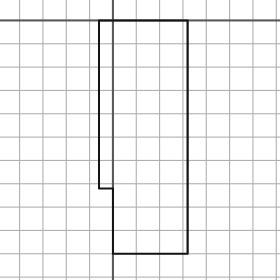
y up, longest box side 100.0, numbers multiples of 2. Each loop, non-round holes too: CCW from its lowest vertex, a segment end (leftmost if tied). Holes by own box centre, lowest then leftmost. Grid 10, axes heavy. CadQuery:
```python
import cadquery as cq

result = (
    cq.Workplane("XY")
    .moveTo(0.0, -100.0)
    .lineTo(32.0, -100.0)
    .lineTo(32.0, 0.0)
    .lineTo(-6.0, 0.0)
    .lineTo(-6.0, -72.0)
    .lineTo(0.0, -72.0)
    .close()
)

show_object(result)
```